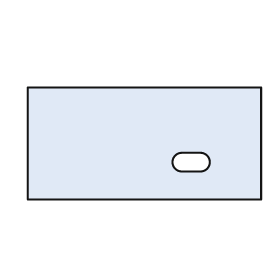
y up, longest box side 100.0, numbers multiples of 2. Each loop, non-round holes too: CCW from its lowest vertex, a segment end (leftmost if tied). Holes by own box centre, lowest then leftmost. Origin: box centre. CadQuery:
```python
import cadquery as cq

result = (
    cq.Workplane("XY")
    .moveTo(-50.0, -24.0)
    .lineTo(50.0, -24.0)
    .lineTo(50.0, 24.0)
    .lineTo(-50.0, 24.0)
    .close()
    .moveTo(16.0, -12.0)
    .lineTo(24.0, -12.0)
    .threePointArc((28.0, -8.0), (24.0, -4.0))
    .lineTo(16.0, -4.0)
    .threePointArc((12.0, -8.0), (16.0, -12.0))
    .close()
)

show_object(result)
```